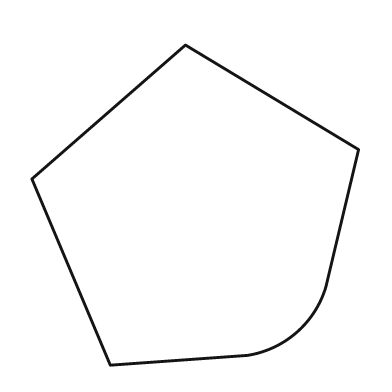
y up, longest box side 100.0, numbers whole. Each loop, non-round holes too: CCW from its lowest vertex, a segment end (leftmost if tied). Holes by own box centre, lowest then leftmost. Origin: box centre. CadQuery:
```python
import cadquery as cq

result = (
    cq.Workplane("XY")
    .moveTo(-26.0, -49.0)
    .lineTo(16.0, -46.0)
    .threePointArc((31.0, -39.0), (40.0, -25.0))
    .lineTo(50.0, 17.0)
    .lineTo(-3.0, 49.0)
    .lineTo(-50.0, 8.0)
    .close()
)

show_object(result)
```